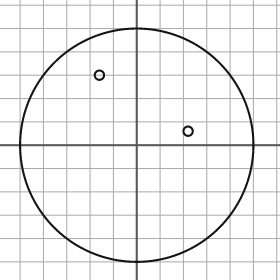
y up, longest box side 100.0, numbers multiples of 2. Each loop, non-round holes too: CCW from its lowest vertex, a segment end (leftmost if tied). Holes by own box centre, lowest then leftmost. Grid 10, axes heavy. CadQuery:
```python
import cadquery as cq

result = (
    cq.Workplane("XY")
    .moveTo(0.0, 0.0)
    .circle(50.0)
    .moveTo(22.0, 6.0)
    .circle(2.0)
    .moveTo(-16.0, 30.0)
    .circle(2.0)
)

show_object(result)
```